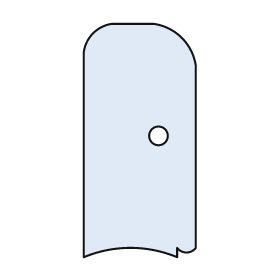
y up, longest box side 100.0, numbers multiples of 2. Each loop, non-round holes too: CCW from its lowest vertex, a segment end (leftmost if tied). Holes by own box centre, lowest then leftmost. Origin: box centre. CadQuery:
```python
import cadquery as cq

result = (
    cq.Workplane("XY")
    .moveTo(-24.0, -50.0)
    .threePointArc((-4.0, -46.0), (16.0, -50.0))
    .lineTo(16.0, -46.0)
    .threePointArc((20.0, -48.0), (24.0, -46.0))
    .lineTo(24.0, 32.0)
    .threePointArc((18.0, 44.0), (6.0, 50.0))
    .lineTo(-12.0, 50.0)
    .threePointArc((-20.0, 46.0), (-24.0, 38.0))
    .close()
    .moveTo(8.0, 2.0)
    .circle(4.0)
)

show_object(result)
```